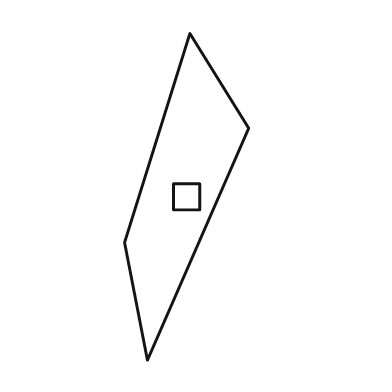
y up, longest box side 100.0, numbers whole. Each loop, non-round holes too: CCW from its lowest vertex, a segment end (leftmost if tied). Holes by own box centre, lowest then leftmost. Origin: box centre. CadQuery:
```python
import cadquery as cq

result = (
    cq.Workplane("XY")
    .moveTo(-12.0, -50.0)
    .lineTo(19.0, 21.0)
    .lineTo(1.0, 50.0)
    .lineTo(-19.0, -14.0)
    .close()
    .moveTo(-4.0, -4.0)
    .lineTo(4.0, -4.0)
    .lineTo(4.0, 4.0)
    .lineTo(-4.0, 4.0)
    .close()
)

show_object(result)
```